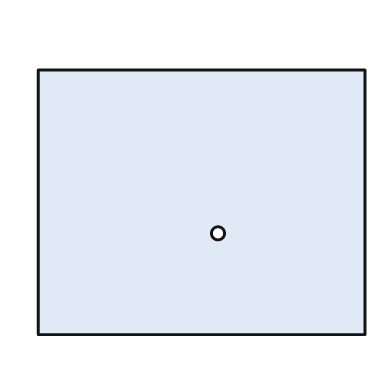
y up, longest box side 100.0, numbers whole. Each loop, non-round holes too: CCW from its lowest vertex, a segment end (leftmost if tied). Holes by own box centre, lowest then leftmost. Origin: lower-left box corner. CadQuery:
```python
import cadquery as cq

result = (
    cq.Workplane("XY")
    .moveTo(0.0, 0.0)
    .lineTo(100.0, 0.0)
    .lineTo(100.0, 81.0)
    .lineTo(0.0, 81.0)
    .close()
    .moveTo(55.0, 31.0)
    .circle(2.0)
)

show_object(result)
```